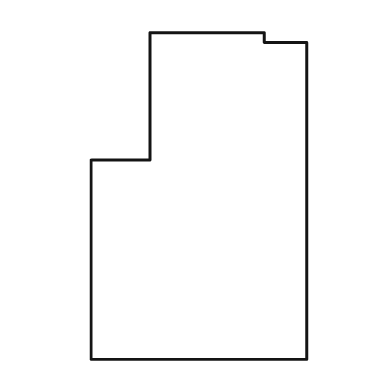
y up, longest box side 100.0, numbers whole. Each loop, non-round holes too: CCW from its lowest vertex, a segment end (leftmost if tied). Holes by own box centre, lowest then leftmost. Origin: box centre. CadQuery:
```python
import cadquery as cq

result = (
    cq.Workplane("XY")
    .moveTo(-33.0, -50.0)
    .lineTo(33.0, -50.0)
    .lineTo(33.0, 47.0)
    .lineTo(20.0, 47.0)
    .lineTo(20.0, 50.0)
    .lineTo(-15.0, 50.0)
    .lineTo(-15.0, 11.0)
    .lineTo(-33.0, 11.0)
    .close()
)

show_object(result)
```